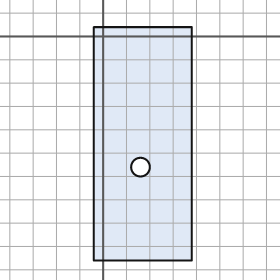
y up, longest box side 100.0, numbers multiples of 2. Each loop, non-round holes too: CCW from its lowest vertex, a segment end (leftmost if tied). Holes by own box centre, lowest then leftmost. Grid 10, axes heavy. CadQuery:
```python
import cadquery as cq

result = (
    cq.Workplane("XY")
    .moveTo(-4.0, -96.0)
    .lineTo(38.0, -96.0)
    .lineTo(38.0, 4.0)
    .lineTo(-4.0, 4.0)
    .close()
    .moveTo(16.0, -56.0)
    .circle(4.0)
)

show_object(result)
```